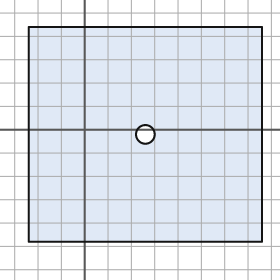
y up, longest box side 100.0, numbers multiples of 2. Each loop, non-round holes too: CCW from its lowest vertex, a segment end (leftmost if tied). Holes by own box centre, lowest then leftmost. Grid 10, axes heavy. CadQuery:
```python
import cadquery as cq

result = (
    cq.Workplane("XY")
    .moveTo(-24.0, -48.0)
    .lineTo(76.0, -48.0)
    .lineTo(76.0, 44.0)
    .lineTo(-24.0, 44.0)
    .close()
    .moveTo(26.0, -2.0)
    .circle(4.0)
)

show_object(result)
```